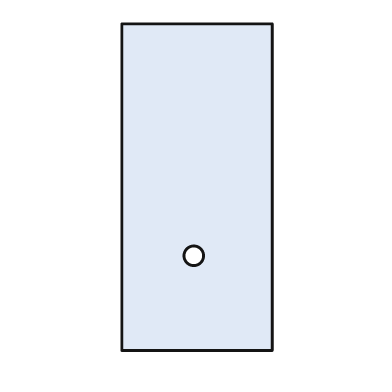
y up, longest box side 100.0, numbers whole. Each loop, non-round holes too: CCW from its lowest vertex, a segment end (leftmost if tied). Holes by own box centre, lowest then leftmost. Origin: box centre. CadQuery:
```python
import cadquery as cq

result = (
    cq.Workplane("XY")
    .moveTo(-23.0, -50.0)
    .lineTo(23.0, -50.0)
    .lineTo(23.0, 50.0)
    .lineTo(-23.0, 50.0)
    .close()
    .moveTo(-1.0, -21.0)
    .circle(3.0)
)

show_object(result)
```